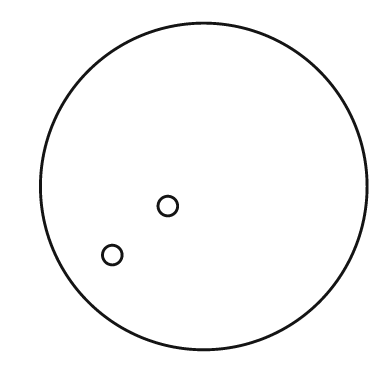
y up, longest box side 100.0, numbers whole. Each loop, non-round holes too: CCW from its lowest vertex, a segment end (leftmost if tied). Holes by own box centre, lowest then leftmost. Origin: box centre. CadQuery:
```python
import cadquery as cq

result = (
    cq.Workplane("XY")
    .moveTo(0.0, 0.0)
    .circle(50.0)
    .moveTo(-28.0, -21.0)
    .circle(3.0)
    .moveTo(-11.0, -6.0)
    .circle(3.0)
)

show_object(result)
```